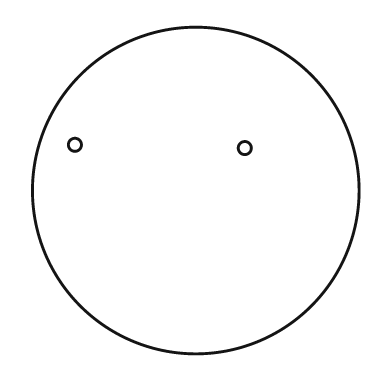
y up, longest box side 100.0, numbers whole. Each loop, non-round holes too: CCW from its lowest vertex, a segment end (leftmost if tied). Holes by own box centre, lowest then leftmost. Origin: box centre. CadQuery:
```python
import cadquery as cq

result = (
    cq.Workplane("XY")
    .moveTo(0.0, 0.0)
    .circle(50.0)
    .moveTo(15.0, 13.0)
    .circle(2.0)
    .moveTo(-37.0, 14.0)
    .circle(2.0)
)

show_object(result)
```